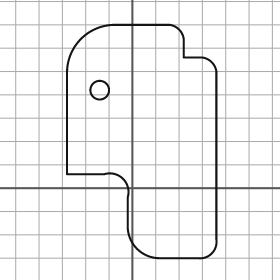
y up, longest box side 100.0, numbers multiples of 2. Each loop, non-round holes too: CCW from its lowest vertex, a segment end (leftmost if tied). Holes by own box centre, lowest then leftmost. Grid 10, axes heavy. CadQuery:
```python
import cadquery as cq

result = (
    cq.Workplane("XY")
    .moveTo(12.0, -30.0)
    .lineTo(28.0, -30.0)
    .threePointArc((34.0, -28.0), (36.0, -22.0))
    .lineTo(36.0, 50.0)
    .threePointArc((34.0, 54.0), (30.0, 56.0))
    .lineTo(22.0, 56.0)
    .lineTo(22.0, 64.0)
    .threePointArc((20.0, 68.0), (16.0, 70.0))
    .lineTo(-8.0, 70.0)
    .threePointArc((-22.0, 64.0), (-28.0, 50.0))
    .lineTo(-28.0, 6.0)
    .lineTo(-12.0, 6.0)
    .threePointArc((-4.0, 4.0), (-2.0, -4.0))
    .lineTo(-2.0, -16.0)
    .threePointArc((2.0, -26.0), (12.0, -30.0))
    .close()
    .moveTo(-14.0, 42.0)
    .circle(4.0)
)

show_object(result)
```